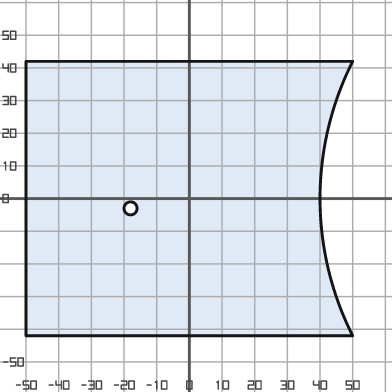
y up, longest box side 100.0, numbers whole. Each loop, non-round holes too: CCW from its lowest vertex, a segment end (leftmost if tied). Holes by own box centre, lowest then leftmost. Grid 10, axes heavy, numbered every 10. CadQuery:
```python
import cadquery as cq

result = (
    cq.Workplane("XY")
    .moveTo(-50.0, -42.0)
    .lineTo(50.0, -42.0)
    .threePointArc((40.0, 0.0), (50.0, 42.0))
    .lineTo(-50.0, 42.0)
    .close()
    .moveTo(-18.0, -3.0)
    .circle(2.0)
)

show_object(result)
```